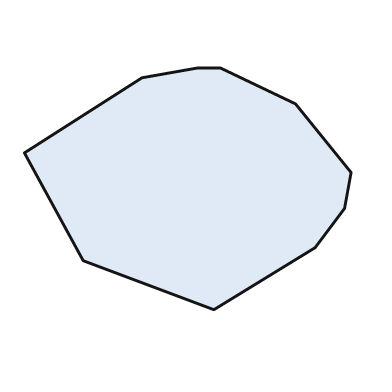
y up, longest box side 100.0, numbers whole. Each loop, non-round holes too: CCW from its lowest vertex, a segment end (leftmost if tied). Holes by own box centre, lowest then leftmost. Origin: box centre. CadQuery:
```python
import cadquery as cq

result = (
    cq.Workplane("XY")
    .moveTo(8.0, -37.0)
    .lineTo(39.0, -18.0)
    .lineTo(48.0, -6.0)
    .lineTo(50.0, 5.0)
    .lineTo(33.0, 26.0)
    .lineTo(10.0, 37.0)
    .lineTo(3.0, 37.0)
    .lineTo(-14.0, 34.0)
    .lineTo(-50.0, 11.0)
    .lineTo(-32.0, -22.0)
    .close()
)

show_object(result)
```